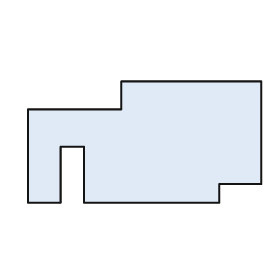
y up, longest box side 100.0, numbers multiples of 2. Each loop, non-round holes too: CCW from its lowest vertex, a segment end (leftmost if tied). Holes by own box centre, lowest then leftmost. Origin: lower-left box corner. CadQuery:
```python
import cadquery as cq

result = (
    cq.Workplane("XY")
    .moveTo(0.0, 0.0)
    .lineTo(14.0, 0.0)
    .lineTo(14.0, 24.0)
    .lineTo(24.0, 24.0)
    .lineTo(24.0, 0.0)
    .lineTo(82.0, 0.0)
    .lineTo(82.0, 8.0)
    .lineTo(100.0, 8.0)
    .lineTo(100.0, 52.0)
    .lineTo(40.0, 52.0)
    .lineTo(40.0, 40.0)
    .lineTo(0.0, 40.0)
    .close()
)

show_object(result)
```